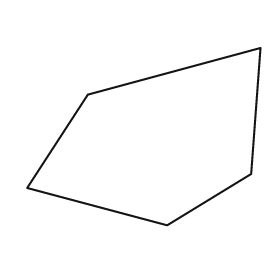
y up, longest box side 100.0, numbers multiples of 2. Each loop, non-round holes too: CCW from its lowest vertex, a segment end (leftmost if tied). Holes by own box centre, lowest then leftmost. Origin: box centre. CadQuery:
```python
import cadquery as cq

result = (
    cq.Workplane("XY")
    .moveTo(10.0, -38.0)
    .lineTo(46.0, -16.0)
    .lineTo(50.0, 38.0)
    .lineTo(-24.0, 18.0)
    .lineTo(-50.0, -22.0)
    .close()
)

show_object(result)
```